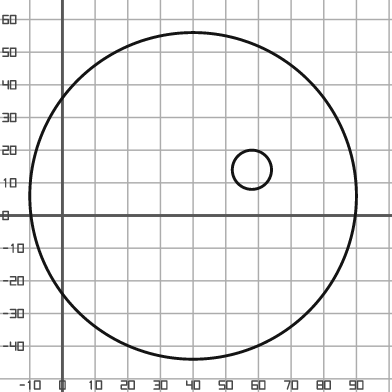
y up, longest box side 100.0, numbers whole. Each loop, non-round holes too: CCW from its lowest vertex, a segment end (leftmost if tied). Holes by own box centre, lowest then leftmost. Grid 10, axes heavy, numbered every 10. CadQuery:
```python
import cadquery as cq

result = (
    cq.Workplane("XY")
    .moveTo(40.0, 6.0)
    .circle(50.0)
    .moveTo(58.0, 14.0)
    .circle(6.0)
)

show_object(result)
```